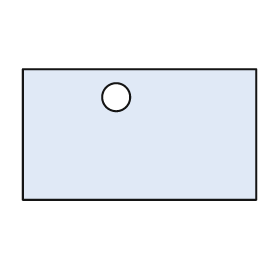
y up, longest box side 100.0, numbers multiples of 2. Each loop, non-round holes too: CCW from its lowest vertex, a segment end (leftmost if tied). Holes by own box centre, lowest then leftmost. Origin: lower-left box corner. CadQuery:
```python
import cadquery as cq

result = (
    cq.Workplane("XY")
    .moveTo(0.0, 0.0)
    .lineTo(100.0, 0.0)
    .lineTo(100.0, 56.0)
    .lineTo(0.0, 56.0)
    .close()
    .moveTo(40.0, 44.0)
    .circle(6.0)
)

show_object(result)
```